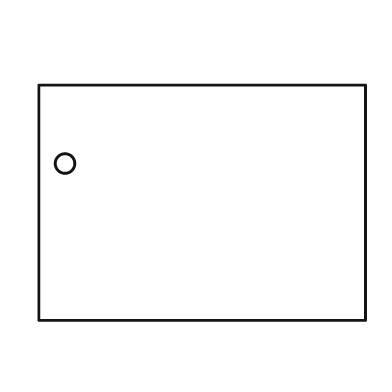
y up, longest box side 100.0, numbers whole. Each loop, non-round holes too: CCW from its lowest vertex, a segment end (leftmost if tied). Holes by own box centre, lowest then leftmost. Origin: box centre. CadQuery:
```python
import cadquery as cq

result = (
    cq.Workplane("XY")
    .moveTo(-50.0, -36.0)
    .lineTo(50.0, -36.0)
    .lineTo(50.0, 36.0)
    .lineTo(-50.0, 36.0)
    .close()
    .moveTo(-42.0, 12.0)
    .circle(3.0)
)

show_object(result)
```